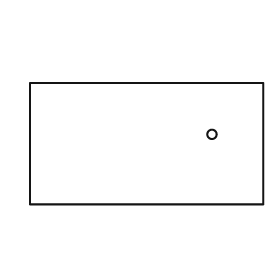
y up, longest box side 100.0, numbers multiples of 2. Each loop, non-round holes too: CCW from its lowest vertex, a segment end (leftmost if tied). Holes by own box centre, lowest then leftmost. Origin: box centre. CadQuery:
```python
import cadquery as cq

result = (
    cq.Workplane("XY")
    .moveTo(-50.0, -26.0)
    .lineTo(50.0, -26.0)
    .lineTo(50.0, 26.0)
    .lineTo(-50.0, 26.0)
    .close()
    .moveTo(28.0, 4.0)
    .circle(2.0)
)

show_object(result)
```